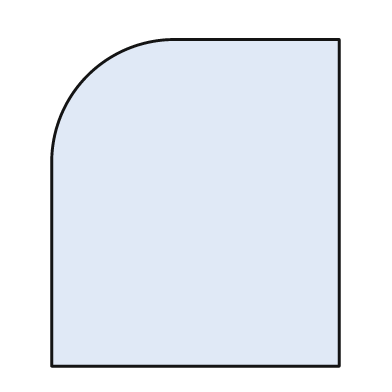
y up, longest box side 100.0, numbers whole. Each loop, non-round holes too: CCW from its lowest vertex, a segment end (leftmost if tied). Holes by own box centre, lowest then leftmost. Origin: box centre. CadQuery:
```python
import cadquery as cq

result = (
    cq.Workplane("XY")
    .moveTo(-44.0, -50.0)
    .lineTo(44.0, -50.0)
    .lineTo(44.0, 50.0)
    .lineTo(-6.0, 50.0)
    .threePointArc((-33.0, 39.0), (-44.0, 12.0))
    .close()
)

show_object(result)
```